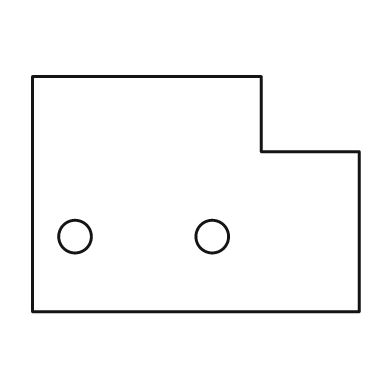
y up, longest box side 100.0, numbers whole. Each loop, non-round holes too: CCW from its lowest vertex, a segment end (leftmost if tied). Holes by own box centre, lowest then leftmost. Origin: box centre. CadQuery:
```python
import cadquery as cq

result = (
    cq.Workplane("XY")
    .moveTo(-50.0, -36.0)
    .lineTo(50.0, -36.0)
    .lineTo(50.0, 13.0)
    .lineTo(20.0, 13.0)
    .lineTo(20.0, 36.0)
    .lineTo(-50.0, 36.0)
    .close()
    .moveTo(-37.0, -13.0)
    .circle(5.0)
    .moveTo(5.0, -13.0)
    .circle(5.0)
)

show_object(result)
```